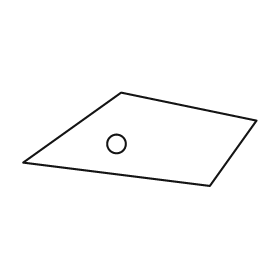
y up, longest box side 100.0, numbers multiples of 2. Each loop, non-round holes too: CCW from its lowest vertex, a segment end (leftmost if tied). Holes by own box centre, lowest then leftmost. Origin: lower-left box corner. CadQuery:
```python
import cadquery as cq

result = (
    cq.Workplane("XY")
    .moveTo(80.0, 0.0)
    .lineTo(100.0, 28.0)
    .lineTo(42.0, 40.0)
    .lineTo(0.0, 10.0)
    .close()
    .moveTo(40.0, 18.0)
    .circle(4.0)
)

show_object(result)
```